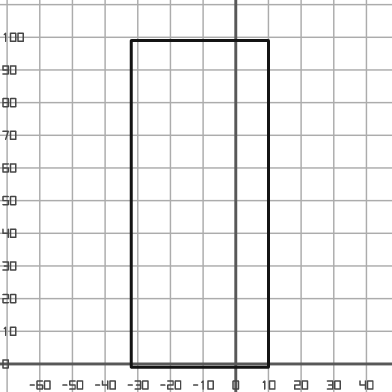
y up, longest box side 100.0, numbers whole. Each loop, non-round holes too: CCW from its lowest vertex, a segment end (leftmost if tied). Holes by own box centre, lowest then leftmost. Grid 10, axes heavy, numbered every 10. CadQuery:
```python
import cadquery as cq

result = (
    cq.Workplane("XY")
    .moveTo(-32.0, -1.0)
    .lineTo(10.0, -1.0)
    .lineTo(10.0, 99.0)
    .lineTo(-32.0, 99.0)
    .close()
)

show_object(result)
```